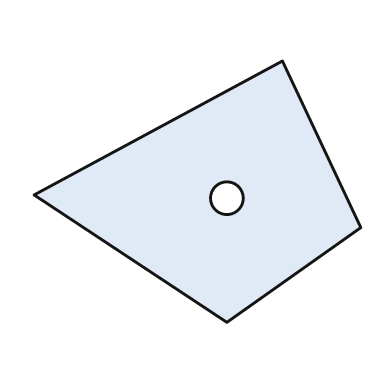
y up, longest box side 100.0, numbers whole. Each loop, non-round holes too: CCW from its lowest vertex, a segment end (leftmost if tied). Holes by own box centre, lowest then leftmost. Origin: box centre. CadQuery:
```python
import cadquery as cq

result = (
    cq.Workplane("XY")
    .moveTo(9.0, -40.0)
    .lineTo(50.0, -11.0)
    .lineTo(26.0, 40.0)
    .lineTo(-50.0, -1.0)
    .close()
    .moveTo(9.0, -2.0)
    .circle(5.0)
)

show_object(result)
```